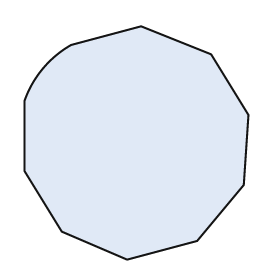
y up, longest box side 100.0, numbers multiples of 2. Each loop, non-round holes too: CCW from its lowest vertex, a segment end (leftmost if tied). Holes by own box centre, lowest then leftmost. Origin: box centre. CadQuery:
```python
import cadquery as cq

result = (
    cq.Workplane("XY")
    .moveTo(-4.0, -50.0)
    .lineTo(26.0, -42.0)
    .lineTo(46.0, -18.0)
    .lineTo(48.0, 12.0)
    .lineTo(32.0, 38.0)
    .lineTo(2.0, 50.0)
    .lineTo(-28.0, 42.0)
    .threePointArc((-40.0, 32.0), (-48.0, 18.0))
    .lineTo(-48.0, -12.0)
    .lineTo(-32.0, -38.0)
    .close()
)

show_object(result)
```